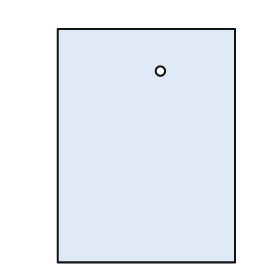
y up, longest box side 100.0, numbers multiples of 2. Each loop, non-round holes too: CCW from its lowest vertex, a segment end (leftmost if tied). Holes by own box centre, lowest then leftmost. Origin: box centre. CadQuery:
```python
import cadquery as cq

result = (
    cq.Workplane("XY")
    .moveTo(-38.0, -50.0)
    .lineTo(38.0, -50.0)
    .lineTo(38.0, 50.0)
    .lineTo(-38.0, 50.0)
    .close()
    .moveTo(6.0, 32.0)
    .circle(2.0)
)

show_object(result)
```